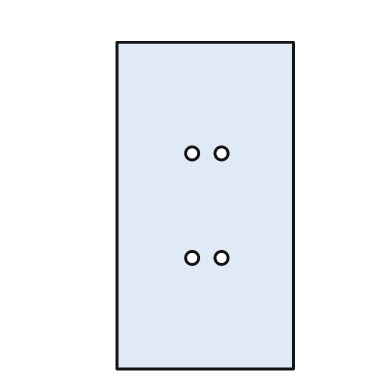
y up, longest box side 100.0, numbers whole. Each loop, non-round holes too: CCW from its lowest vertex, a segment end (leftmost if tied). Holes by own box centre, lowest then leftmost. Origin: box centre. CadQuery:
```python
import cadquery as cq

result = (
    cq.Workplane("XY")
    .moveTo(-27.0, -50.0)
    .lineTo(27.0, -50.0)
    .lineTo(27.0, 50.0)
    .lineTo(-27.0, 50.0)
    .close()
    .moveTo(-4.0, -16.0)
    .circle(2.0)
    .moveTo(5.0, -16.0)
    .circle(2.0)
    .moveTo(-4.0, 16.0)
    .circle(2.0)
    .moveTo(5.0, 16.0)
    .circle(2.0)
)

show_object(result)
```